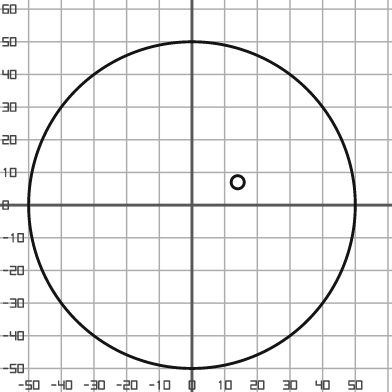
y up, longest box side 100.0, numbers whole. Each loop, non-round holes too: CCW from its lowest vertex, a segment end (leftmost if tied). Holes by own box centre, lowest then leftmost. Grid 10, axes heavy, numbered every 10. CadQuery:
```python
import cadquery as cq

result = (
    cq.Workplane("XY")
    .moveTo(0.0, 0.0)
    .circle(50.0)
    .moveTo(14.0, 7.0)
    .circle(2.0)
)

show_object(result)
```